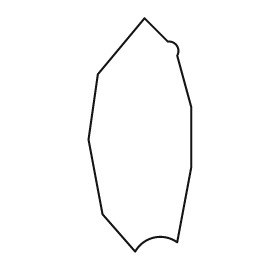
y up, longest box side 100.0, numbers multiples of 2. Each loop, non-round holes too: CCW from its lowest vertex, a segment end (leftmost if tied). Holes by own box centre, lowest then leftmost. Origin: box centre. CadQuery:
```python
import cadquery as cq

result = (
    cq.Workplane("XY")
    .moveTo(-2.0, -50.0)
    .threePointArc((6.0, -44.0), (16.0, -46.0))
    .lineTo(22.0, -14.0)
    .lineTo(22.0, 12.0)
    .lineTo(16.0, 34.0)
    .threePointArc((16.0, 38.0), (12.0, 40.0))
    .lineTo(2.0, 50.0)
    .lineTo(-18.0, 26.0)
    .lineTo(-22.0, -2.0)
    .lineTo(-16.0, -34.0)
    .close()
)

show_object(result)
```